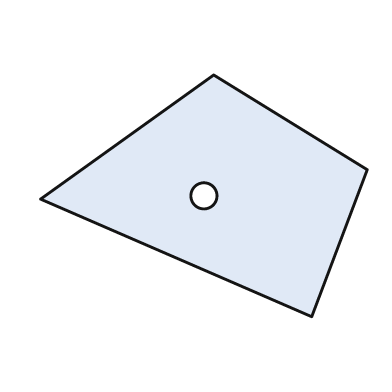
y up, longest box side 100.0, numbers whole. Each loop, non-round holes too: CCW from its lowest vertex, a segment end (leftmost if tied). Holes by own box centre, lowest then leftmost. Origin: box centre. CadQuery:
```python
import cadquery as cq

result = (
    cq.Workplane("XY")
    .moveTo(33.0, -37.0)
    .lineTo(50.0, 8.0)
    .lineTo(3.0, 37.0)
    .lineTo(-50.0, -1.0)
    .close()
    .moveTo(0.0, 0.0)
    .circle(4.0)
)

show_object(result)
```